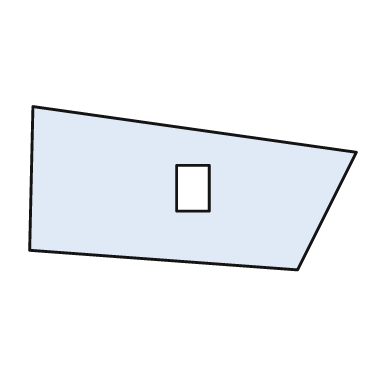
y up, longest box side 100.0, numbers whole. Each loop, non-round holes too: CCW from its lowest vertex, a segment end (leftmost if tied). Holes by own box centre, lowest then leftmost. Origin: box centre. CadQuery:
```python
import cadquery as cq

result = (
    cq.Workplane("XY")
    .moveTo(32.0, -25.0)
    .lineTo(50.0, 11.0)
    .lineTo(-49.0, 25.0)
    .lineTo(-50.0, -19.0)
    .close()
    .moveTo(-5.0, -7.0)
    .lineTo(5.0, -7.0)
    .lineTo(5.0, 7.0)
    .lineTo(-5.0, 7.0)
    .close()
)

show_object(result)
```